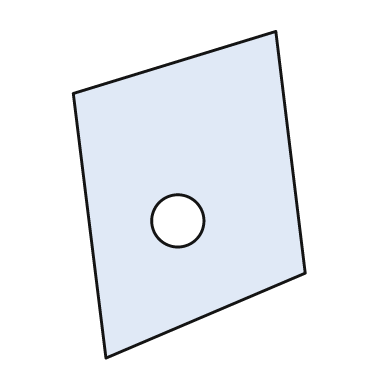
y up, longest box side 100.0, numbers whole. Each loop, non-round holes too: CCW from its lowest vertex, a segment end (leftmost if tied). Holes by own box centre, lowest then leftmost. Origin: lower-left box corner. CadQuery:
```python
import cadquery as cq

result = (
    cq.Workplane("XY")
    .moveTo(10.0, 0.0)
    .lineTo(71.0, 26.0)
    .lineTo(62.0, 100.0)
    .lineTo(0.0, 81.0)
    .close()
    .moveTo(32.0, 42.0)
    .circle(8.0)
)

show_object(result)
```